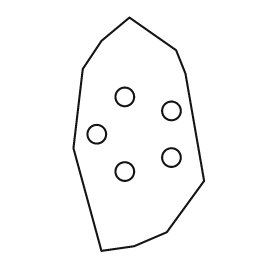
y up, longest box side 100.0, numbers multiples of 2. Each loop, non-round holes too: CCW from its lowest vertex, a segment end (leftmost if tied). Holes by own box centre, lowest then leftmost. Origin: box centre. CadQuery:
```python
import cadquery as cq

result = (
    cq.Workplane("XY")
    .moveTo(-16.0, -50.0)
    .lineTo(-2.0, -48.0)
    .lineTo(12.0, -42.0)
    .lineTo(28.0, -20.0)
    .lineTo(20.0, 26.0)
    .lineTo(16.0, 36.0)
    .lineTo(-4.0, 50.0)
    .lineTo(-16.0, 40.0)
    .lineTo(-24.0, 28.0)
    .lineTo(-28.0, -6.0)
    .close()
    .moveTo(-6.0, -16.0)
    .circle(4.0)
    .moveTo(14.0, -10.0)
    .circle(4.0)
    .moveTo(-18.0, 0.0)
    .circle(4.0)
    .moveTo(14.0, 10.0)
    .circle(4.0)
    .moveTo(-6.0, 16.0)
    .circle(4.0)
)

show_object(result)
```